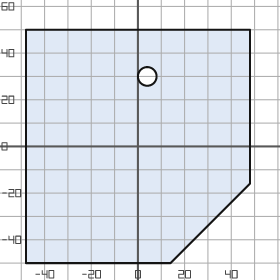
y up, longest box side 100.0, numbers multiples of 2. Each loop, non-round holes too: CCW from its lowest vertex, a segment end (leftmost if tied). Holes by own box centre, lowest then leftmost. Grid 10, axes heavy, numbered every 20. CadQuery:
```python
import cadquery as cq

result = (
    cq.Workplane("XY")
    .moveTo(-48.0, -50.0)
    .lineTo(14.0, -50.0)
    .lineTo(48.0, -16.0)
    .lineTo(48.0, 50.0)
    .lineTo(-48.0, 50.0)
    .close()
    .moveTo(4.0, 30.0)
    .circle(4.0)
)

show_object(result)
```